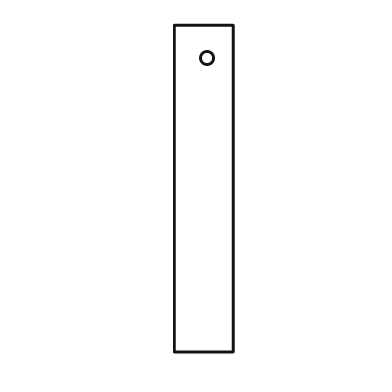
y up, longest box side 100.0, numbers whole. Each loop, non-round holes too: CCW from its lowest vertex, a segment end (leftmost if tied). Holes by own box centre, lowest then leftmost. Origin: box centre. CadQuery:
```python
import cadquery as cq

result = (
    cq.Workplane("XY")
    .moveTo(-9.0, -50.0)
    .lineTo(9.0, -50.0)
    .lineTo(9.0, 50.0)
    .lineTo(-9.0, 50.0)
    .close()
    .moveTo(1.0, 40.0)
    .circle(2.0)
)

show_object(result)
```